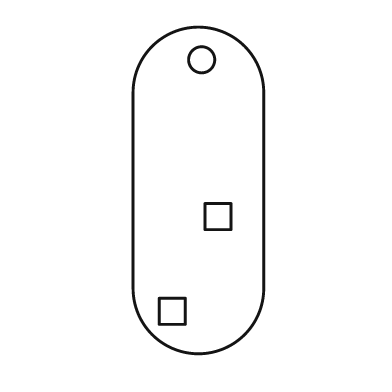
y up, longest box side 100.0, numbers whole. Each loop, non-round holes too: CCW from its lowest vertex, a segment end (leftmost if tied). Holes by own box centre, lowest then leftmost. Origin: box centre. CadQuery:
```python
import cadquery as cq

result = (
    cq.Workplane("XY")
    .moveTo(-20.0, -30.0)
    .threePointArc((0.0, -50.0), (20.0, -30.0))
    .lineTo(20.0, 30.0)
    .threePointArc((0.0, 50.0), (-20.0, 30.0))
    .close()
    .moveTo(-12.0, -41.0)
    .lineTo(-4.0, -41.0)
    .lineTo(-4.0, -33.0)
    .lineTo(-12.0, -33.0)
    .close()
    .moveTo(2.0, -12.0)
    .lineTo(10.0, -12.0)
    .lineTo(10.0, -4.0)
    .lineTo(2.0, -4.0)
    .close()
    .moveTo(1.0, 40.0)
    .circle(4.0)
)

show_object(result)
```